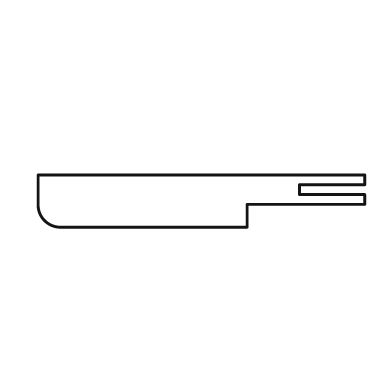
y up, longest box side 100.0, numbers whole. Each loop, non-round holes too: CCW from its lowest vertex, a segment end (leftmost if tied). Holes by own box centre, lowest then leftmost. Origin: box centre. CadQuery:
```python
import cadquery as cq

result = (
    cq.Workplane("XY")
    .moveTo(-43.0, -8.0)
    .lineTo(14.0, -8.0)
    .lineTo(14.0, -1.0)
    .lineTo(50.0, -1.0)
    .lineTo(50.0, 2.0)
    .lineTo(30.0, 2.0)
    .lineTo(30.0, 5.0)
    .lineTo(50.0, 5.0)
    .lineTo(50.0, 8.0)
    .lineTo(-50.0, 8.0)
    .lineTo(-50.0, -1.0)
    .threePointArc((-48.0, -6.0), (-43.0, -8.0))
    .close()
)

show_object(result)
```